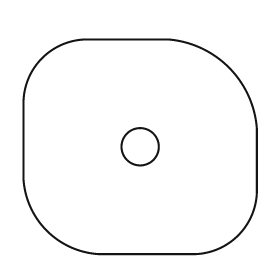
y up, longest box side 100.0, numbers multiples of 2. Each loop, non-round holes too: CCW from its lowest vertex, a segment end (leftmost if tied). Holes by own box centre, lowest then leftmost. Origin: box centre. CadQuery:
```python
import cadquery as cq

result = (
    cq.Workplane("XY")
    .moveTo(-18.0, -46.0)
    .lineTo(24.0, -46.0)
    .threePointArc((42.0, -38.0), (50.0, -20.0))
    .lineTo(50.0, 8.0)
    .threePointArc((38.0, 34.0), (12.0, 46.0))
    .lineTo(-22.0, 46.0)
    .threePointArc((-42.0, 38.0), (-50.0, 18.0))
    .lineTo(-50.0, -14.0)
    .threePointArc((-40.0, -36.0), (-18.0, -46.0))
    .close()
    .moveTo(0.0, 0.0)
    .circle(8.0)
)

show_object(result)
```